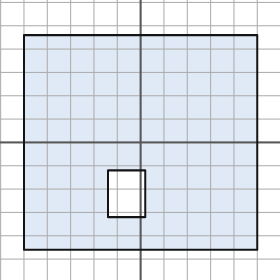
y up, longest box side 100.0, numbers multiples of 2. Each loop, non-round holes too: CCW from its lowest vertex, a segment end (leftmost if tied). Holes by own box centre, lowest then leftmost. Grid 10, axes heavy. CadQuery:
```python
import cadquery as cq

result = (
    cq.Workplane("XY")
    .moveTo(-50.0, -46.0)
    .lineTo(50.0, -46.0)
    .lineTo(50.0, 46.0)
    .lineTo(-50.0, 46.0)
    .close()
    .moveTo(-14.0, -32.0)
    .lineTo(2.0, -32.0)
    .lineTo(2.0, -12.0)
    .lineTo(-14.0, -12.0)
    .close()
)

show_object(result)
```